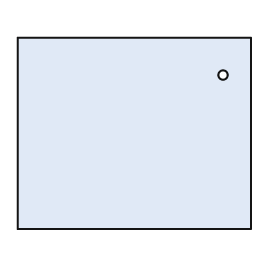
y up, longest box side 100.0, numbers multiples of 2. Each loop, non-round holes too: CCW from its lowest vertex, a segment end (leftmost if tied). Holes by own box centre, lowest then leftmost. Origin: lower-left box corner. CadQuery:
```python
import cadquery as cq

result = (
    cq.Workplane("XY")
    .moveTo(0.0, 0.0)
    .lineTo(100.0, 0.0)
    .lineTo(100.0, 82.0)
    .lineTo(0.0, 82.0)
    .close()
    .moveTo(88.0, 66.0)
    .circle(2.0)
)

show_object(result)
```